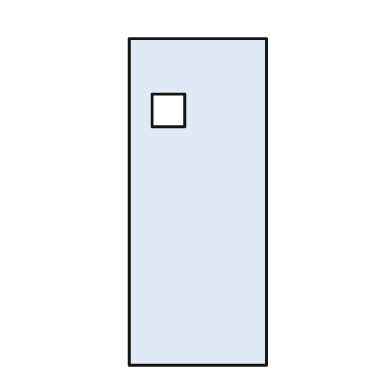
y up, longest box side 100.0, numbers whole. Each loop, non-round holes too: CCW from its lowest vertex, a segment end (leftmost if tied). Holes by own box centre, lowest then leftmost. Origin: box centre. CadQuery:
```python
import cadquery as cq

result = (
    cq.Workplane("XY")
    .moveTo(-21.0, -50.0)
    .lineTo(21.0, -50.0)
    .lineTo(21.0, 50.0)
    .lineTo(-21.0, 50.0)
    .close()
    .moveTo(-14.0, 23.0)
    .lineTo(-4.0, 23.0)
    .lineTo(-4.0, 33.0)
    .lineTo(-14.0, 33.0)
    .close()
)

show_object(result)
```